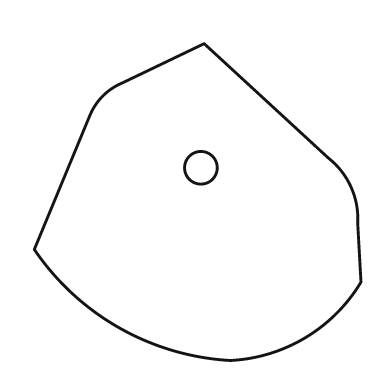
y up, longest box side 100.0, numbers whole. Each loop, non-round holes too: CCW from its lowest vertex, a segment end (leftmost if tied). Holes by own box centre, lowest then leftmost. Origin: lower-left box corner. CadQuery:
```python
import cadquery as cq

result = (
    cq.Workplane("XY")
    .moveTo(60.0, 0.0)
    .threePointArc((83.0, 7.0), (100.0, 24.0))
    .lineTo(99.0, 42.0)
    .threePointArc((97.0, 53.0), (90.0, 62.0))
    .lineTo(52.0, 97.0)
    .lineTo(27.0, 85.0)
    .threePointArc((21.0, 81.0), (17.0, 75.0))
    .lineTo(0.0, 34.0)
    .threePointArc((26.0, 10.0), (60.0, 0.0))
    .close()
    .moveTo(51.0, 59.0)
    .circle(5.0)
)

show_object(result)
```